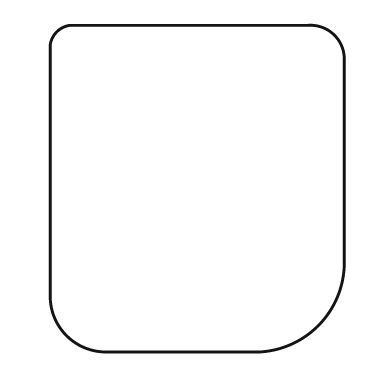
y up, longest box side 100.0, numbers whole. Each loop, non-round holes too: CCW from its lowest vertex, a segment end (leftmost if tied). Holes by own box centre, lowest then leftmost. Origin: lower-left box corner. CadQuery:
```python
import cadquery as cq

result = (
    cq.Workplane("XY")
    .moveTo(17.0, 0.0)
    .lineTo(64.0, 0.0)
    .threePointArc((82.0, 8.0), (90.0, 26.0))
    .lineTo(90.0, 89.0)
    .threePointArc((87.0, 97.0), (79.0, 100.0))
    .lineTo(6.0, 100.0)
    .threePointArc((2.0, 98.0), (0.0, 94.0))
    .lineTo(0.0, 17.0)
    .threePointArc((5.0, 5.0), (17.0, 0.0))
    .close()
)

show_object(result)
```